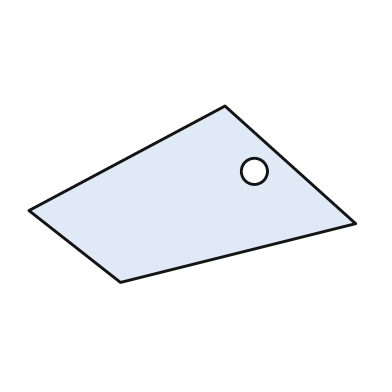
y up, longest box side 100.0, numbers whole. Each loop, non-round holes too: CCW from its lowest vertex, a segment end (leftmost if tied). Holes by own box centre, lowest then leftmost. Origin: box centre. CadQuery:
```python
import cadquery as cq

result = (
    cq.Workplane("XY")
    .moveTo(-22.0, -27.0)
    .lineTo(50.0, -9.0)
    .lineTo(10.0, 27.0)
    .lineTo(-50.0, -5.0)
    .close()
    .moveTo(19.0, 7.0)
    .circle(4.0)
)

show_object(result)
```